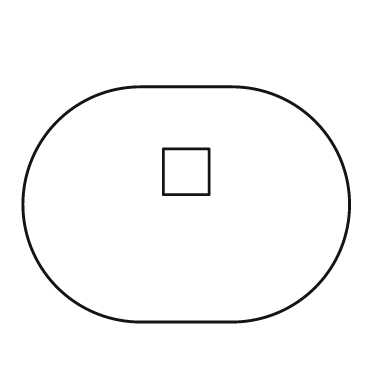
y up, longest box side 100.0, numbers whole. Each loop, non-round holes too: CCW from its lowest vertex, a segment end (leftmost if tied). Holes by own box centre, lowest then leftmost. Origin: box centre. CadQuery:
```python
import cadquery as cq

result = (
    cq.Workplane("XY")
    .moveTo(-14.0, -36.0)
    .lineTo(14.0, -36.0)
    .threePointArc((50.0, 0.0), (14.0, 36.0))
    .lineTo(-14.0, 36.0)
    .threePointArc((-50.0, 0.0), (-14.0, -36.0))
    .close()
    .moveTo(-7.0, 3.0)
    .lineTo(7.0, 3.0)
    .lineTo(7.0, 17.0)
    .lineTo(-7.0, 17.0)
    .close()
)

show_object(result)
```